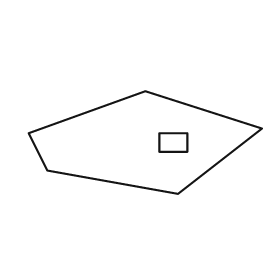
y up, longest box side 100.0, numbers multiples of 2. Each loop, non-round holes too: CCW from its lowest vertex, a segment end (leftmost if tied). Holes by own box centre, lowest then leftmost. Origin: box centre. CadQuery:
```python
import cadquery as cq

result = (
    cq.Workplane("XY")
    .moveTo(14.0, -22.0)
    .lineTo(50.0, 6.0)
    .lineTo(0.0, 22.0)
    .lineTo(-50.0, 4.0)
    .lineTo(-42.0, -12.0)
    .close()
    .moveTo(6.0, -4.0)
    .lineTo(18.0, -4.0)
    .lineTo(18.0, 4.0)
    .lineTo(6.0, 4.0)
    .close()
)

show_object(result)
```